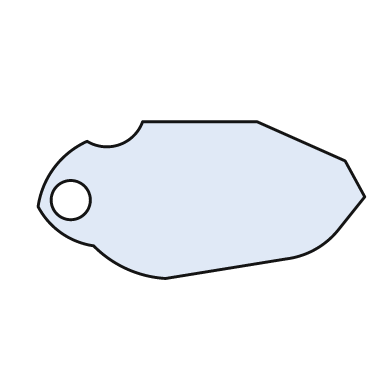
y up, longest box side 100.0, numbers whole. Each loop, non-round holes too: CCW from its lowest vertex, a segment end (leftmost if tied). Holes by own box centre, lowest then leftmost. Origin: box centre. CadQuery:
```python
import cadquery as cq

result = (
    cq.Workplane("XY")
    .moveTo(-11.0, -24.0)
    .lineTo(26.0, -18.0)
    .threePointArc((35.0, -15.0), (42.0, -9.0))
    .lineTo(50.0, 1.0)
    .lineTo(44.0, 12.0)
    .lineTo(17.0, 24.0)
    .lineTo(-18.0, 24.0)
    .threePointArc((-25.0, 17.0), (-35.0, 18.0))
    .threePointArc((-45.0, 10.0), (-50.0, -2.0))
    .threePointArc((-43.0, -10.0), (-33.0, -14.0))
    .threePointArc((-23.0, -21.0), (-11.0, -24.0))
    .close()
    .moveTo(-40.0, 0.0)
    .circle(6.0)
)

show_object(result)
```